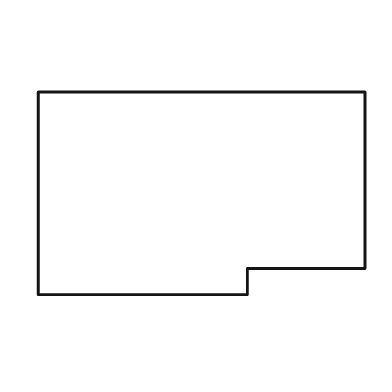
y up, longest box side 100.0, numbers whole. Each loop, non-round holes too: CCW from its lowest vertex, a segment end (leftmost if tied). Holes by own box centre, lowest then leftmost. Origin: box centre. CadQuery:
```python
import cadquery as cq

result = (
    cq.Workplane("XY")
    .moveTo(-50.0, -31.0)
    .lineTo(14.0, -31.0)
    .lineTo(14.0, -23.0)
    .lineTo(50.0, -23.0)
    .lineTo(50.0, 31.0)
    .lineTo(-50.0, 31.0)
    .close()
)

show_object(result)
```